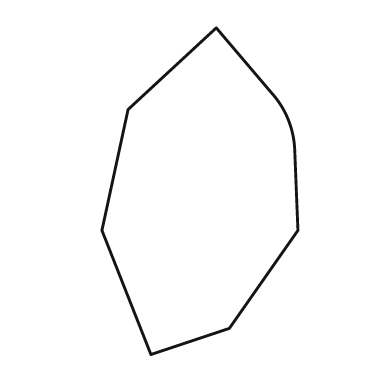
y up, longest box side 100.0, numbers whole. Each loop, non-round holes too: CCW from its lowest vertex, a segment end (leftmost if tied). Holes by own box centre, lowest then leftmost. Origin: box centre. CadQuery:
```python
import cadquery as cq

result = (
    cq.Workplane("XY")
    .moveTo(-15.0, -50.0)
    .lineTo(9.0, -42.0)
    .lineTo(30.0, -12.0)
    .lineTo(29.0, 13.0)
    .threePointArc((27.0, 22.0), (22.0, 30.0))
    .lineTo(5.0, 50.0)
    .lineTo(-22.0, 25.0)
    .lineTo(-30.0, -12.0)
    .close()
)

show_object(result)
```